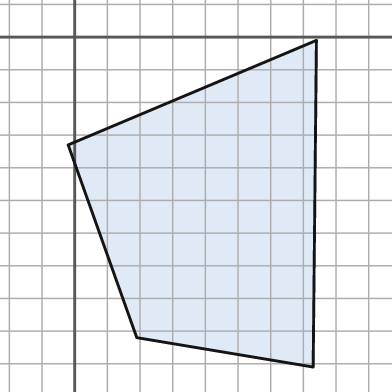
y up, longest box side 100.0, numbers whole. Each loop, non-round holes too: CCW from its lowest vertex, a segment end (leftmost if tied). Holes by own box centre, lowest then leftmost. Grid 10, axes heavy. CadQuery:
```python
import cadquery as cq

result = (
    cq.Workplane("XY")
    .moveTo(73.0, -101.0)
    .lineTo(74.0, -1.0)
    .lineTo(-2.0, -33.0)
    .lineTo(19.0, -92.0)
    .close()
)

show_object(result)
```